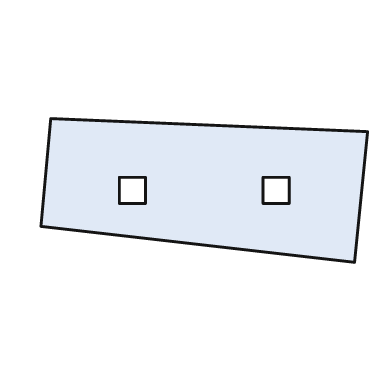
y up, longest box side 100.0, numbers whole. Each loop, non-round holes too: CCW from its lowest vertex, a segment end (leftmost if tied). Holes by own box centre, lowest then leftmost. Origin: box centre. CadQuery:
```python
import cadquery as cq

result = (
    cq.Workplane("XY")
    .moveTo(46.0, -22.0)
    .lineTo(50.0, 18.0)
    .lineTo(-47.0, 22.0)
    .lineTo(-50.0, -11.0)
    .close()
    .moveTo(-26.0, -4.0)
    .lineTo(-18.0, -4.0)
    .lineTo(-18.0, 4.0)
    .lineTo(-26.0, 4.0)
    .close()
    .moveTo(18.0, -4.0)
    .lineTo(26.0, -4.0)
    .lineTo(26.0, 4.0)
    .lineTo(18.0, 4.0)
    .close()
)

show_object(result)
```